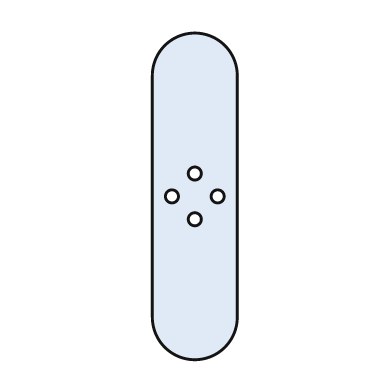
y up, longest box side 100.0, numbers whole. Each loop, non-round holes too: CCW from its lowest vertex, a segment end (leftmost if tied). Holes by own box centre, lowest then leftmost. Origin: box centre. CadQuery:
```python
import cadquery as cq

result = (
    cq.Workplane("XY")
    .moveTo(-13.0, -37.0)
    .threePointArc((0.0, -50.0), (13.0, -37.0))
    .lineTo(13.0, 37.0)
    .threePointArc((0.0, 50.0), (-13.0, 37.0))
    .close()
    .moveTo(0.0, -7.0)
    .circle(2.0)
    .moveTo(-7.0, 0.0)
    .circle(2.0)
    .moveTo(7.0, 0.0)
    .circle(2.0)
    .moveTo(0.0, 7.0)
    .circle(2.0)
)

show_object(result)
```